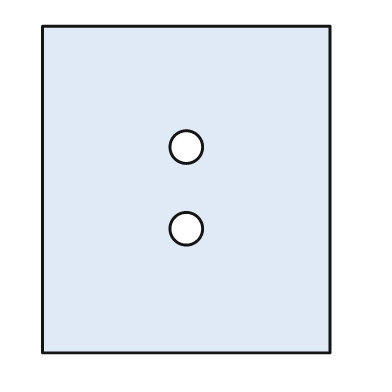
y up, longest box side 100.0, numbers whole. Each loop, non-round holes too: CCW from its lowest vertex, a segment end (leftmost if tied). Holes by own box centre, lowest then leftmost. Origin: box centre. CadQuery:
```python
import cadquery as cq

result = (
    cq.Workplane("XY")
    .moveTo(-44.0, -50.0)
    .lineTo(44.0, -50.0)
    .lineTo(44.0, 50.0)
    .lineTo(-44.0, 50.0)
    .close()
    .moveTo(0.0, -12.0)
    .circle(5.0)
    .moveTo(0.0, 13.0)
    .circle(5.0)
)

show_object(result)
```